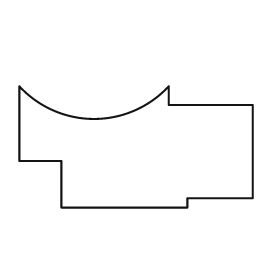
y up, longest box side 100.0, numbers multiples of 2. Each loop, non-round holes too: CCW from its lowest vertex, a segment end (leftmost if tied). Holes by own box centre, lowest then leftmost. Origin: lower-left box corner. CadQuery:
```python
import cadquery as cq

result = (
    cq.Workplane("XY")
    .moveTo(18.0, 0.0)
    .lineTo(72.0, 0.0)
    .lineTo(72.0, 4.0)
    .lineTo(100.0, 4.0)
    .lineTo(100.0, 44.0)
    .lineTo(64.0, 44.0)
    .lineTo(64.0, 52.0)
    .threePointArc((32.0, 38.0), (0.0, 52.0))
    .lineTo(0.0, 20.0)
    .lineTo(18.0, 20.0)
    .close()
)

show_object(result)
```